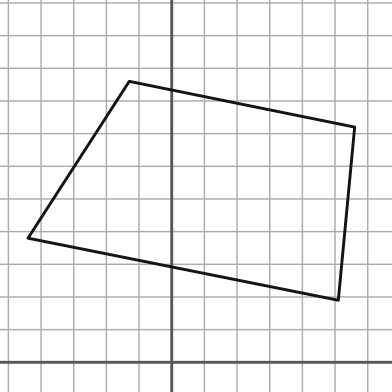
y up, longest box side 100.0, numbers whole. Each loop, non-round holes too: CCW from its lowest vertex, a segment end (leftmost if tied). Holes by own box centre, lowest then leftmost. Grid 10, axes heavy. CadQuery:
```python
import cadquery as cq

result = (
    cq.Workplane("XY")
    .moveTo(51.0, 19.0)
    .lineTo(56.0, 72.0)
    .lineTo(-13.0, 86.0)
    .lineTo(-44.0, 38.0)
    .close()
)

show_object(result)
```